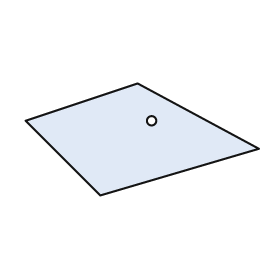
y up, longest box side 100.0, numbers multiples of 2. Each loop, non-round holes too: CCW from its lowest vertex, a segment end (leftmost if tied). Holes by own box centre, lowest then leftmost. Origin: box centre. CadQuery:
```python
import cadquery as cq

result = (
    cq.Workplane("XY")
    .moveTo(-18.0, -24.0)
    .lineTo(50.0, -4.0)
    .lineTo(-2.0, 24.0)
    .lineTo(-50.0, 8.0)
    .close()
    .moveTo(4.0, 8.0)
    .circle(2.0)
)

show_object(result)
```